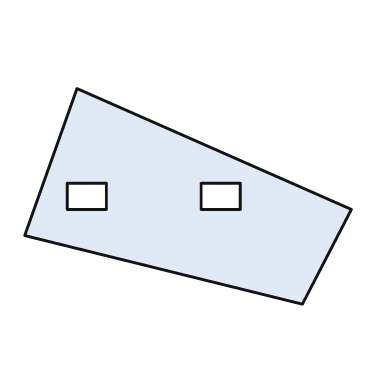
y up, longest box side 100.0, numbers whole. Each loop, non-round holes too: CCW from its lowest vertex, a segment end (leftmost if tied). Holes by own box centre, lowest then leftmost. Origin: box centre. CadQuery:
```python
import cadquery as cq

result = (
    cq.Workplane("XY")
    .moveTo(35.0, -33.0)
    .lineTo(50.0, -4.0)
    .lineTo(-34.0, 33.0)
    .lineTo(-50.0, -12.0)
    .close()
    .moveTo(-37.0, -4.0)
    .lineTo(-25.0, -4.0)
    .lineTo(-25.0, 4.0)
    .lineTo(-37.0, 4.0)
    .close()
    .moveTo(4.0, -4.0)
    .lineTo(16.0, -4.0)
    .lineTo(16.0, 4.0)
    .lineTo(4.0, 4.0)
    .close()
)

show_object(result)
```